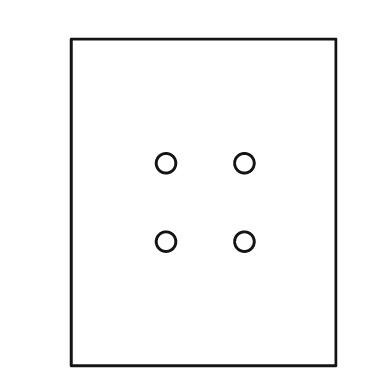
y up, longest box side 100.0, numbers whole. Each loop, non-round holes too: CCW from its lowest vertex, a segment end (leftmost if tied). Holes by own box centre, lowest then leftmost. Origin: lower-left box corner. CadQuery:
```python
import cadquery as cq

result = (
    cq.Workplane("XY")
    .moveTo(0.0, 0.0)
    .lineTo(81.0, 0.0)
    .lineTo(81.0, 100.0)
    .lineTo(0.0, 100.0)
    .close()
    .moveTo(29.0, 38.0)
    .circle(3.0)
    .moveTo(53.0, 38.0)
    .circle(3.0)
    .moveTo(29.0, 62.0)
    .circle(3.0)
    .moveTo(53.0, 62.0)
    .circle(3.0)
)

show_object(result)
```